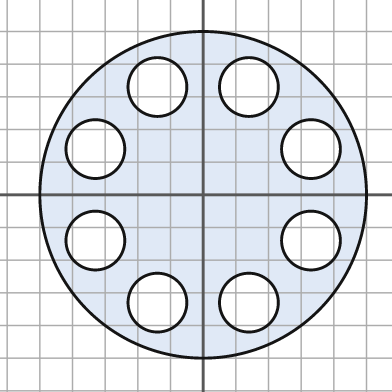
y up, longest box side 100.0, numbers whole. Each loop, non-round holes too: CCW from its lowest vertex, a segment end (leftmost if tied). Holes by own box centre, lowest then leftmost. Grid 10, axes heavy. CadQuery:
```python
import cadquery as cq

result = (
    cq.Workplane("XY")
    .moveTo(0.0, 0.0)
    .circle(50.0)
    .moveTo(-14.0, -33.0)
    .circle(9.0)
    .moveTo(14.0, -33.0)
    .circle(9.0)
    .moveTo(-33.0, -14.0)
    .circle(9.0)
    .moveTo(33.0, -14.0)
    .circle(9.0)
    .moveTo(-33.0, 14.0)
    .circle(9.0)
    .moveTo(33.0, 14.0)
    .circle(9.0)
    .moveTo(-14.0, 33.0)
    .circle(9.0)
    .moveTo(14.0, 33.0)
    .circle(9.0)
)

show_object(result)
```